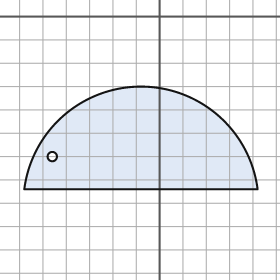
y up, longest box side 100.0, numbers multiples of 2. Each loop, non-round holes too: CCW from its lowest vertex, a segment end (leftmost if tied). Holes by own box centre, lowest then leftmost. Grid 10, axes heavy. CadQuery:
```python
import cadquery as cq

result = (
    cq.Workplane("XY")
    .moveTo(-58.0, -74.0)
    .lineTo(42.0, -74.0)
    .threePointArc((-8.0, -30.0), (-58.0, -74.0))
    .close()
    .moveTo(-46.0, -60.0)
    .circle(2.0)
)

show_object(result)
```